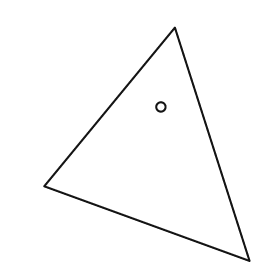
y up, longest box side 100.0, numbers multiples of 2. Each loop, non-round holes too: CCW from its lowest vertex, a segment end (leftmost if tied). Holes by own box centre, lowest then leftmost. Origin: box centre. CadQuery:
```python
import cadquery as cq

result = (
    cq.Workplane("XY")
    .moveTo(44.0, -50.0)
    .lineTo(12.0, 50.0)
    .lineTo(-44.0, -18.0)
    .close()
    .moveTo(6.0, 16.0)
    .circle(2.0)
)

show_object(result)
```